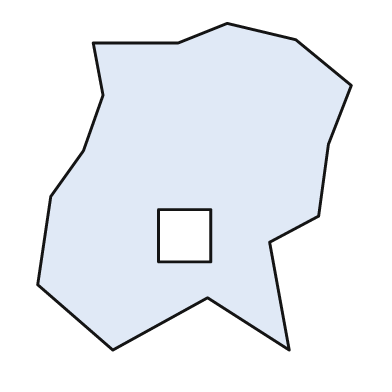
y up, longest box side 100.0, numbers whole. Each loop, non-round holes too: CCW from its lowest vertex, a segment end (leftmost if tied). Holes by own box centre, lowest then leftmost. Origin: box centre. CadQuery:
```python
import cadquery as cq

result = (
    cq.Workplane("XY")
    .moveTo(-25.0, -50.0)
    .lineTo(4.0, -34.0)
    .lineTo(29.0, -50.0)
    .lineTo(23.0, -17.0)
    .lineTo(38.0, -9.0)
    .lineTo(41.0, 13.0)
    .lineTo(48.0, 31.0)
    .lineTo(31.0, 45.0)
    .lineTo(10.0, 50.0)
    .lineTo(-5.0, 44.0)
    .lineTo(-31.0, 44.0)
    .lineTo(-28.0, 28.0)
    .lineTo(-34.0, 11.0)
    .lineTo(-44.0, -3.0)
    .lineTo(-48.0, -30.0)
    .close()
    .moveTo(-11.0, -23.0)
    .lineTo(5.0, -23.0)
    .lineTo(5.0, -7.0)
    .lineTo(-11.0, -7.0)
    .close()
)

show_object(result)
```